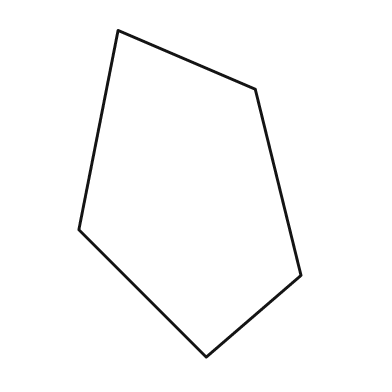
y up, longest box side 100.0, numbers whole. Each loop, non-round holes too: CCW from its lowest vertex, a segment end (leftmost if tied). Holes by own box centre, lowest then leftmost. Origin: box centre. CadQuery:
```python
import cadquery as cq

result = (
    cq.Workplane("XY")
    .moveTo(5.0, -50.0)
    .lineTo(34.0, -25.0)
    .lineTo(20.0, 32.0)
    .lineTo(-22.0, 50.0)
    .lineTo(-34.0, -11.0)
    .close()
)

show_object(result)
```